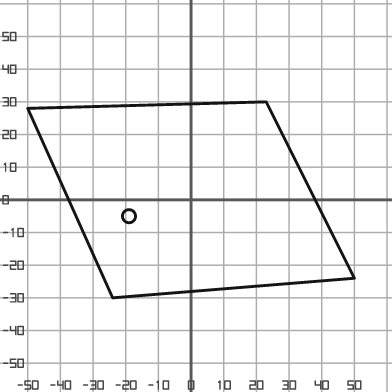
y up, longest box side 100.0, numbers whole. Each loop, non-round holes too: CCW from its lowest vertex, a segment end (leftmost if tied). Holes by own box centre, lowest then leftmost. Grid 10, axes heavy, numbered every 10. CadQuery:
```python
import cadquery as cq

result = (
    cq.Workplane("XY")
    .moveTo(-24.0, -30.0)
    .lineTo(50.0, -24.0)
    .lineTo(23.0, 30.0)
    .lineTo(-50.0, 28.0)
    .close()
    .moveTo(-19.0, -5.0)
    .circle(2.0)
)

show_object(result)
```